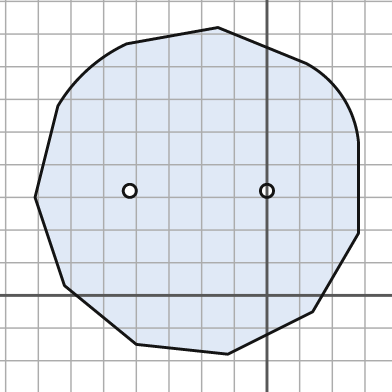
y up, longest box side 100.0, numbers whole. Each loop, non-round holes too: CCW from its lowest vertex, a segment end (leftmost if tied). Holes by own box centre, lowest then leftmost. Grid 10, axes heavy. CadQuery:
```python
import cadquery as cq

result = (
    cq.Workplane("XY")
    .moveTo(-12.0, -18.0)
    .lineTo(14.0, -5.0)
    .lineTo(28.0, 19.0)
    .lineTo(28.0, 47.0)
    .threePointArc((23.0, 61.0), (12.0, 71.0))
    .lineTo(-15.0, 82.0)
    .lineTo(-43.0, 77.0)
    .threePointArc((-55.0, 69.0), (-64.0, 58.0))
    .lineTo(-71.0, 30.0)
    .lineTo(-62.0, 3.0)
    .lineTo(-40.0, -15.0)
    .close()
    .moveTo(-42.0, 32.0)
    .circle(2.0)
    .moveTo(0.0, 32.0)
    .circle(2.0)
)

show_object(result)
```